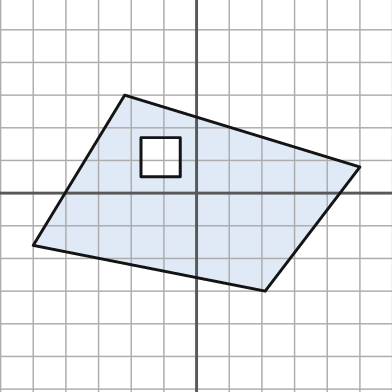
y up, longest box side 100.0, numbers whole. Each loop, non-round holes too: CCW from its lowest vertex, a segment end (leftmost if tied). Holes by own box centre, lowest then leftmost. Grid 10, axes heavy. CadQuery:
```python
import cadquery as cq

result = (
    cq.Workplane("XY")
    .moveTo(21.0, -30.0)
    .lineTo(50.0, 8.0)
    .lineTo(-22.0, 30.0)
    .lineTo(-50.0, -16.0)
    .close()
    .moveTo(-17.0, 5.0)
    .lineTo(-5.0, 5.0)
    .lineTo(-5.0, 17.0)
    .lineTo(-17.0, 17.0)
    .close()
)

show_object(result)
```